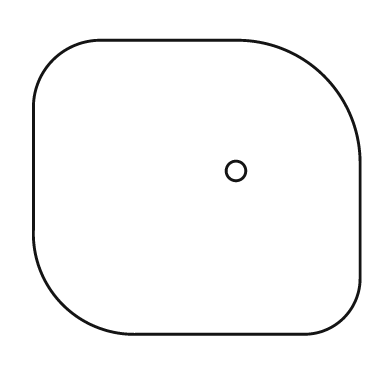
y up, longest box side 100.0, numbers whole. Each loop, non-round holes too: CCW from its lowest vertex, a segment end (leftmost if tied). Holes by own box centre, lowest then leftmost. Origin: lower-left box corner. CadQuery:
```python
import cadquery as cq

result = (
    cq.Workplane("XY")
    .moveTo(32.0, 0.0)
    .lineTo(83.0, 0.0)
    .threePointArc((95.0, 5.0), (100.0, 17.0))
    .lineTo(100.0, 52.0)
    .threePointArc((89.0, 79.0), (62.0, 90.0))
    .lineTo(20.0, 90.0)
    .threePointArc((6.0, 84.0), (0.0, 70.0))
    .lineTo(0.0, 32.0)
    .threePointArc((9.0, 9.0), (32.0, 0.0))
    .close()
    .moveTo(62.0, 50.0)
    .circle(3.0)
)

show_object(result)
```